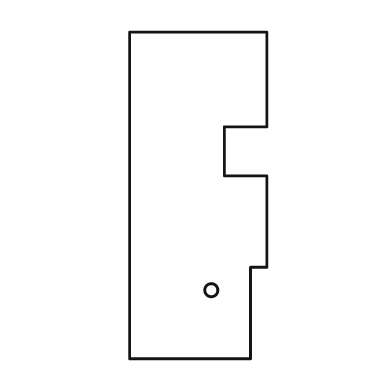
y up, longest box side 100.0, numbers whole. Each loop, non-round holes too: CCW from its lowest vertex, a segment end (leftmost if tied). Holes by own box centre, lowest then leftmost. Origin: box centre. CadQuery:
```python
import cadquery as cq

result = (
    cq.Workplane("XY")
    .moveTo(-21.0, -50.0)
    .lineTo(16.0, -50.0)
    .lineTo(16.0, -22.0)
    .lineTo(21.0, -22.0)
    .lineTo(21.0, 6.0)
    .lineTo(8.0, 6.0)
    .lineTo(8.0, 21.0)
    .lineTo(21.0, 21.0)
    .lineTo(21.0, 50.0)
    .lineTo(-21.0, 50.0)
    .close()
    .moveTo(4.0, -29.0)
    .circle(2.0)
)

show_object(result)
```